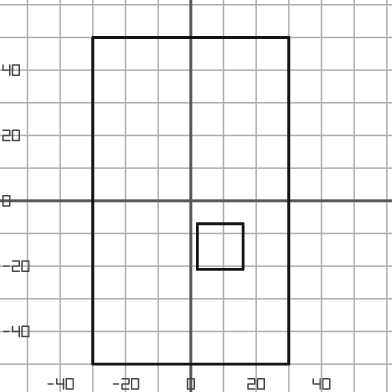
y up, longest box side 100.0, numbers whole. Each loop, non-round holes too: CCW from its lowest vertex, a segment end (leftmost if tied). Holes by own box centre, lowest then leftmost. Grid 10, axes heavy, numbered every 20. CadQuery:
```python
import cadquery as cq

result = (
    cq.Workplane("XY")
    .moveTo(-30.0, -50.0)
    .lineTo(30.0, -50.0)
    .lineTo(30.0, 50.0)
    .lineTo(-30.0, 50.0)
    .close()
    .moveTo(2.0, -21.0)
    .lineTo(16.0, -21.0)
    .lineTo(16.0, -7.0)
    .lineTo(2.0, -7.0)
    .close()
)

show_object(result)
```